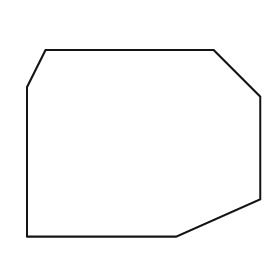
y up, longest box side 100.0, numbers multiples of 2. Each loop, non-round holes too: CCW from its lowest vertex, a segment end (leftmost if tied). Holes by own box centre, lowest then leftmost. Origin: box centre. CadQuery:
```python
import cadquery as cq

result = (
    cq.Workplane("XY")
    .moveTo(-50.0, -40.0)
    .lineTo(14.0, -40.0)
    .lineTo(50.0, -24.0)
    .lineTo(50.0, 20.0)
    .lineTo(30.0, 40.0)
    .lineTo(-42.0, 40.0)
    .lineTo(-50.0, 24.0)
    .close()
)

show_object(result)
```